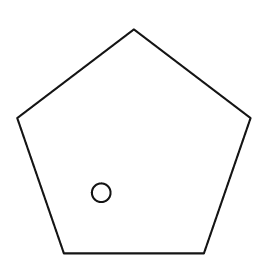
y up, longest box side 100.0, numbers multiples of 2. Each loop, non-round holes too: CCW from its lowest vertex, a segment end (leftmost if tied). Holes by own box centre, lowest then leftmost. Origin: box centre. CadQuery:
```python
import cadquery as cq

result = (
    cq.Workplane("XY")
    .moveTo(-30.0, -48.0)
    .lineTo(30.0, -48.0)
    .lineTo(50.0, 10.0)
    .lineTo(0.0, 48.0)
    .lineTo(-50.0, 10.0)
    .close()
    .moveTo(-14.0, -22.0)
    .circle(4.0)
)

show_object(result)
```